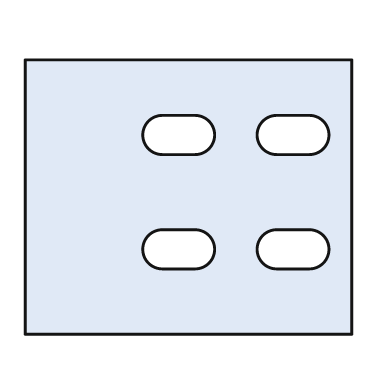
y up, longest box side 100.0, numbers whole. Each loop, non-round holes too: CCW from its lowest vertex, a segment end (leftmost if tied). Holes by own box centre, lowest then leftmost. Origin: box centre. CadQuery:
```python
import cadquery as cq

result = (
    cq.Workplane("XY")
    .moveTo(-50.0, -42.0)
    .lineTo(50.0, -42.0)
    .lineTo(50.0, 42.0)
    .lineTo(-50.0, 42.0)
    .close()
    .moveTo(-8.0, -22.0)
    .lineTo(2.0, -22.0)
    .threePointArc((8.0, -16.0), (2.0, -10.0))
    .lineTo(-8.0, -10.0)
    .threePointArc((-14.0, -16.0), (-8.0, -22.0))
    .close()
    .moveTo(27.0, -22.0)
    .lineTo(37.0, -22.0)
    .threePointArc((43.0, -16.0), (37.0, -10.0))
    .lineTo(27.0, -10.0)
    .threePointArc((21.0, -16.0), (27.0, -22.0))
    .close()
    .moveTo(-8.0, 13.0)
    .lineTo(2.0, 13.0)
    .threePointArc((8.0, 19.0), (2.0, 25.0))
    .lineTo(-8.0, 25.0)
    .threePointArc((-14.0, 19.0), (-8.0, 13.0))
    .close()
    .moveTo(27.0, 13.0)
    .lineTo(37.0, 13.0)
    .threePointArc((43.0, 19.0), (37.0, 25.0))
    .lineTo(27.0, 25.0)
    .threePointArc((21.0, 19.0), (27.0, 13.0))
    .close()
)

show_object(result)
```